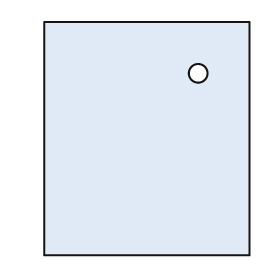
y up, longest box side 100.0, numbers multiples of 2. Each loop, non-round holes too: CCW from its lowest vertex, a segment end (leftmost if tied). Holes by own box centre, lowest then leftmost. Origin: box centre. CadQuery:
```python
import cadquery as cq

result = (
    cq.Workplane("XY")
    .moveTo(-44.0, -50.0)
    .lineTo(44.0, -50.0)
    .lineTo(44.0, 50.0)
    .lineTo(-44.0, 50.0)
    .close()
    .moveTo(22.0, 28.0)
    .circle(4.0)
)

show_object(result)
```